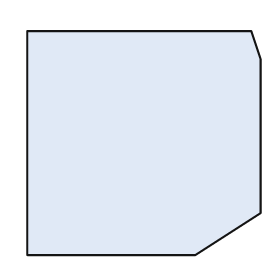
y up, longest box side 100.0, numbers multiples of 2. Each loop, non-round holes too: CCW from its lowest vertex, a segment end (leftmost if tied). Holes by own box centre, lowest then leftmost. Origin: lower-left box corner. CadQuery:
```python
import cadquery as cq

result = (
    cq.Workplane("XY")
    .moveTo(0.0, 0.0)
    .lineTo(72.0, 0.0)
    .lineTo(100.0, 18.0)
    .lineTo(100.0, 84.0)
    .lineTo(96.0, 96.0)
    .lineTo(0.0, 96.0)
    .close()
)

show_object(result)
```